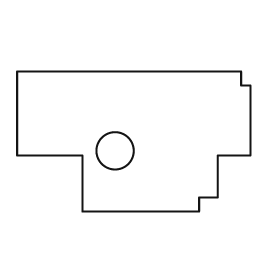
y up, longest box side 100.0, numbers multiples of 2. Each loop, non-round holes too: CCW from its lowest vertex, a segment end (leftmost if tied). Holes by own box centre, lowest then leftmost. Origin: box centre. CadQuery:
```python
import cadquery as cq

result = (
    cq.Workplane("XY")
    .moveTo(-22.0, -30.0)
    .lineTo(28.0, -30.0)
    .lineTo(28.0, -24.0)
    .lineTo(36.0, -24.0)
    .lineTo(36.0, -6.0)
    .lineTo(50.0, -6.0)
    .lineTo(50.0, 24.0)
    .lineTo(46.0, 24.0)
    .lineTo(46.0, 30.0)
    .lineTo(-50.0, 30.0)
    .lineTo(-50.0, -6.0)
    .lineTo(-22.0, -6.0)
    .close()
    .moveTo(-8.0, -4.0)
    .circle(8.0)
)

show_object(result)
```